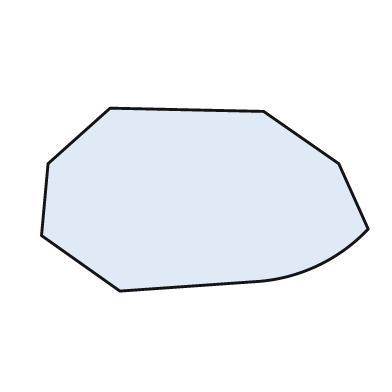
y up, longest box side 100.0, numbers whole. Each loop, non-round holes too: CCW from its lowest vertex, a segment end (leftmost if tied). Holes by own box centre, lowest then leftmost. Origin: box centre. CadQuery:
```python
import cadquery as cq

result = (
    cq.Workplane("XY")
    .moveTo(-26.0, -28.0)
    .lineTo(17.0, -25.0)
    .threePointArc((35.0, -20.0), (50.0, -9.0))
    .lineTo(41.0, 11.0)
    .lineTo(18.0, 27.0)
    .lineTo(-29.0, 28.0)
    .lineTo(-48.0, 11.0)
    .lineTo(-50.0, -11.0)
    .close()
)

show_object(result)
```